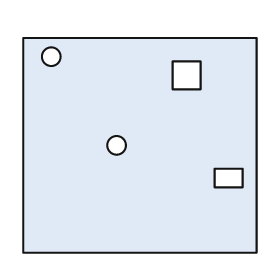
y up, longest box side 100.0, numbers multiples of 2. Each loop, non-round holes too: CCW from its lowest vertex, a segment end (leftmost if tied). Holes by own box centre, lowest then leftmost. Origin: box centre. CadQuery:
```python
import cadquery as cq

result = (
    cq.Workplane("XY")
    .moveTo(-50.0, -46.0)
    .lineTo(50.0, -46.0)
    .lineTo(50.0, 46.0)
    .lineTo(-50.0, 46.0)
    .close()
    .moveTo(32.0, -18.0)
    .lineTo(44.0, -18.0)
    .lineTo(44.0, -10.0)
    .lineTo(32.0, -10.0)
    .close()
    .moveTo(-10.0, 0.0)
    .circle(4.0)
    .moveTo(14.0, 24.0)
    .lineTo(26.0, 24.0)
    .lineTo(26.0, 36.0)
    .lineTo(14.0, 36.0)
    .close()
    .moveTo(-38.0, 38.0)
    .circle(4.0)
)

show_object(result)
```